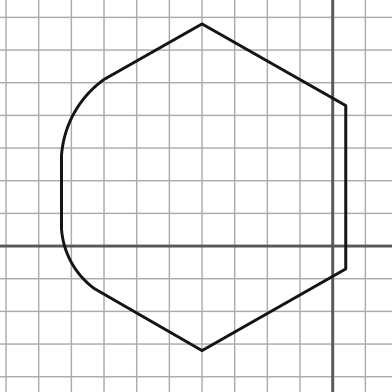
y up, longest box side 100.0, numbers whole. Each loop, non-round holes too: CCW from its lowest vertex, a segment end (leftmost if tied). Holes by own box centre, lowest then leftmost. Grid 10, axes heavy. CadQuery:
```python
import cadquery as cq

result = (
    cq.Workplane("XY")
    .moveTo(-40.0, -32.0)
    .lineTo(4.0, -7.0)
    .lineTo(4.0, 43.0)
    .lineTo(-40.0, 68.0)
    .lineTo(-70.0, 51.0)
    .threePointArc((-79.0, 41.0), (-83.0, 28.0))
    .lineTo(-83.0, 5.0)
    .threePointArc((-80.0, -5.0), (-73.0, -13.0))
    .close()
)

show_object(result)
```